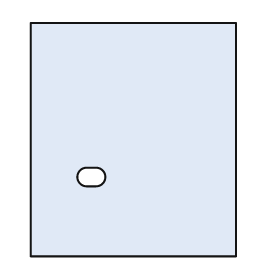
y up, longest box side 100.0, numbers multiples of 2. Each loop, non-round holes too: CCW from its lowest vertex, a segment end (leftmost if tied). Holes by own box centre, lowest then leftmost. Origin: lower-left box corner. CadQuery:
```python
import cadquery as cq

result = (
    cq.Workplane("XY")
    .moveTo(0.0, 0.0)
    .lineTo(88.0, 0.0)
    .lineTo(88.0, 100.0)
    .lineTo(0.0, 100.0)
    .close()
    .moveTo(24.0, 30.0)
    .lineTo(28.0, 30.0)
    .threePointArc((32.0, 34.0), (28.0, 38.0))
    .lineTo(24.0, 38.0)
    .threePointArc((20.0, 34.0), (24.0, 30.0))
    .close()
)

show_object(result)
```